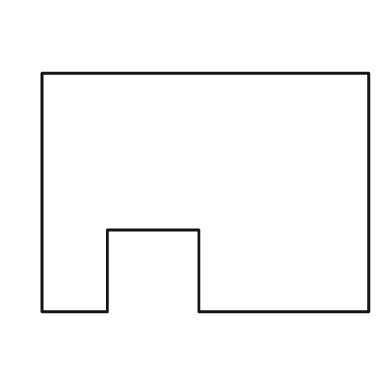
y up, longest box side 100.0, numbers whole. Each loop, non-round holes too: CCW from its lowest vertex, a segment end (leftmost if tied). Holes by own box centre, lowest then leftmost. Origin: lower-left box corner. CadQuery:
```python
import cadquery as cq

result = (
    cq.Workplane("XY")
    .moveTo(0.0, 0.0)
    .lineTo(20.0, 0.0)
    .lineTo(20.0, 25.0)
    .lineTo(48.0, 25.0)
    .lineTo(48.0, 0.0)
    .lineTo(100.0, 0.0)
    .lineTo(100.0, 73.0)
    .lineTo(0.0, 73.0)
    .close()
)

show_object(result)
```